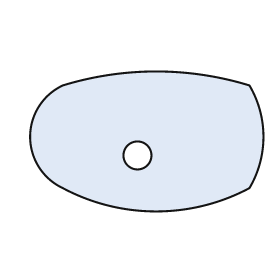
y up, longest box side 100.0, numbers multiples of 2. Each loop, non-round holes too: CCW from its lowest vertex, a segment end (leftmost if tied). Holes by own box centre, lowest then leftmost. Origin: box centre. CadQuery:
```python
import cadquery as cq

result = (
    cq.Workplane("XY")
    .moveTo(-36.0, -20.0)
    .threePointArc((4.0, -30.0), (44.0, -20.0))
    .threePointArc((50.0, 2.0), (44.0, 24.0))
    .threePointArc((4.0, 30.0), (-36.0, 24.0))
    .threePointArc((-50.0, 2.0), (-36.0, -20.0))
    .close()
    .moveTo(-4.0, -6.0)
    .circle(6.0)
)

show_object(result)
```